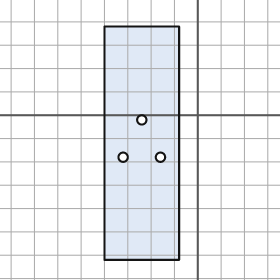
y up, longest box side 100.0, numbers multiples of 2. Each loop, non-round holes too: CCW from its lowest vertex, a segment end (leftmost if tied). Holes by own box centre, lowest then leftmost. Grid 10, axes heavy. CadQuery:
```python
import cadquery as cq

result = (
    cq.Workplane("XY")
    .moveTo(-40.0, -62.0)
    .lineTo(-8.0, -62.0)
    .lineTo(-8.0, 38.0)
    .lineTo(-40.0, 38.0)
    .close()
    .moveTo(-32.0, -18.0)
    .circle(2.0)
    .moveTo(-16.0, -18.0)
    .circle(2.0)
    .moveTo(-24.0, -2.0)
    .circle(2.0)
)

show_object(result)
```